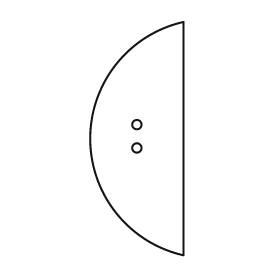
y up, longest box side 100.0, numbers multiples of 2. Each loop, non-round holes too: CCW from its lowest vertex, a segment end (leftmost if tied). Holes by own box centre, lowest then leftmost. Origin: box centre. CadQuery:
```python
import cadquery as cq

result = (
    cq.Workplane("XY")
    .moveTo(20.0, -50.0)
    .lineTo(20.0, 50.0)
    .threePointArc((-20.0, 0.0), (20.0, -50.0))
    .close()
    .moveTo(0.0, -4.0)
    .circle(2.0)
    .moveTo(0.0, 6.0)
    .circle(2.0)
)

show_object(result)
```